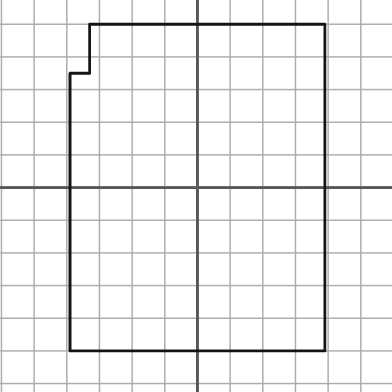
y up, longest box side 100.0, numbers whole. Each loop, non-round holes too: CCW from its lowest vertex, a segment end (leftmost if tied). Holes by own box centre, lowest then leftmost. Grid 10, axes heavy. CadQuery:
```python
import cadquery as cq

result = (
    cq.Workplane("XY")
    .moveTo(-39.0, -50.0)
    .lineTo(39.0, -50.0)
    .lineTo(39.0, 50.0)
    .lineTo(-33.0, 50.0)
    .lineTo(-33.0, 35.0)
    .lineTo(-39.0, 35.0)
    .close()
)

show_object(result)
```